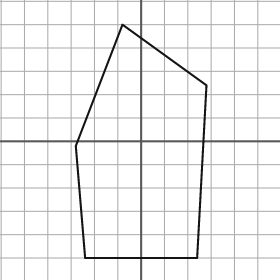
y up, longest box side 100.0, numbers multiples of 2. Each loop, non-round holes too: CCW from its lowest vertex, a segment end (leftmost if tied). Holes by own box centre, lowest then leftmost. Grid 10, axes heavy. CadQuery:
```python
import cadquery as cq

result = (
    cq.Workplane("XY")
    .moveTo(-24.0, -50.0)
    .lineTo(24.0, -50.0)
    .lineTo(28.0, 24.0)
    .lineTo(-8.0, 50.0)
    .lineTo(-28.0, -2.0)
    .close()
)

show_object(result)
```